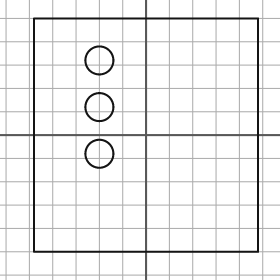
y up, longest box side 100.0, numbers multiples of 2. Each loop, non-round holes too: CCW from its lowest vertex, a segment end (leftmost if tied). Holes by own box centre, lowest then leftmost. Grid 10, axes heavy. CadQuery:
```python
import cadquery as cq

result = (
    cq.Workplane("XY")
    .moveTo(-48.0, -50.0)
    .lineTo(48.0, -50.0)
    .lineTo(48.0, 50.0)
    .lineTo(-48.0, 50.0)
    .close()
    .moveTo(-20.0, -8.0)
    .circle(6.0)
    .moveTo(-20.0, 12.0)
    .circle(6.0)
    .moveTo(-20.0, 32.0)
    .circle(6.0)
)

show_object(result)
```